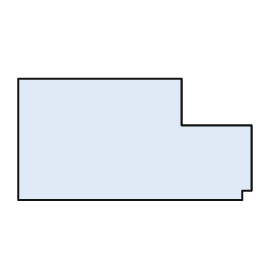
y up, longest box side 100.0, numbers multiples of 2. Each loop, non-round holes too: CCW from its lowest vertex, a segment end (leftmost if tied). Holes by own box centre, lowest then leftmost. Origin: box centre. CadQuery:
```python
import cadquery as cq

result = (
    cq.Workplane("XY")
    .moveTo(-50.0, -26.0)
    .lineTo(46.0, -26.0)
    .lineTo(46.0, -22.0)
    .lineTo(50.0, -22.0)
    .lineTo(50.0, 6.0)
    .lineTo(20.0, 6.0)
    .lineTo(20.0, 26.0)
    .lineTo(-50.0, 26.0)
    .close()
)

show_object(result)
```